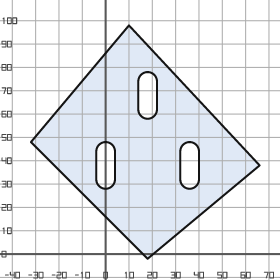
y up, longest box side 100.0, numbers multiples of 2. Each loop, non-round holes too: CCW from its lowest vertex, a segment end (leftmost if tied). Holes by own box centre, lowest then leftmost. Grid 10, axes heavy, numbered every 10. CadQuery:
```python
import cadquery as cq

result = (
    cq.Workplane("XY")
    .moveTo(18.0, -2.0)
    .lineTo(66.0, 38.0)
    .lineTo(10.0, 98.0)
    .lineTo(-32.0, 48.0)
    .close()
    .moveTo(-4.0, 32.0)
    .threePointArc((0.0, 28.0), (4.0, 32.0))
    .lineTo(4.0, 44.0)
    .threePointArc((0.0, 48.0), (-4.0, 44.0))
    .close()
    .moveTo(32.0, 32.0)
    .threePointArc((36.0, 28.0), (40.0, 32.0))
    .lineTo(40.0, 44.0)
    .threePointArc((36.0, 48.0), (32.0, 44.0))
    .close()
    .moveTo(14.0, 62.0)
    .threePointArc((18.0, 58.0), (22.0, 62.0))
    .lineTo(22.0, 74.0)
    .threePointArc((18.0, 78.0), (14.0, 74.0))
    .close()
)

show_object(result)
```